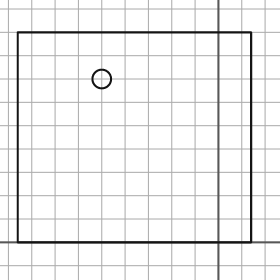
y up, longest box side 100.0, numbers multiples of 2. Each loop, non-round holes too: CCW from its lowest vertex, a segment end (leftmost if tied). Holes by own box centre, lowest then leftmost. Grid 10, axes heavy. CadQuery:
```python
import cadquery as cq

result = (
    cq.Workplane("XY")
    .moveTo(-86.0, 0.0)
    .lineTo(14.0, 0.0)
    .lineTo(14.0, 90.0)
    .lineTo(-86.0, 90.0)
    .close()
    .moveTo(-50.0, 70.0)
    .circle(4.0)
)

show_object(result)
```